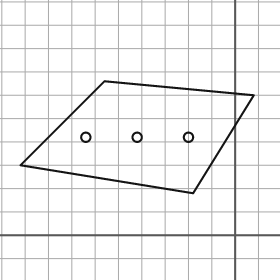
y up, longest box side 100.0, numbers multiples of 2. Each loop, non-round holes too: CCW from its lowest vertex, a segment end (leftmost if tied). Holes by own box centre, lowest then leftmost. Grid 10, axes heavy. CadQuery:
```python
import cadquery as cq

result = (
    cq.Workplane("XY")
    .moveTo(-18.0, 18.0)
    .lineTo(8.0, 60.0)
    .lineTo(-56.0, 66.0)
    .lineTo(-92.0, 30.0)
    .close()
    .moveTo(-64.0, 42.0)
    .circle(2.0)
    .moveTo(-42.0, 42.0)
    .circle(2.0)
    .moveTo(-20.0, 42.0)
    .circle(2.0)
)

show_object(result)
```